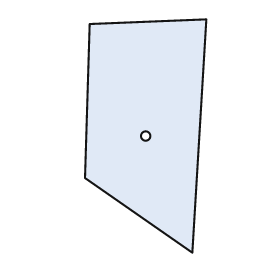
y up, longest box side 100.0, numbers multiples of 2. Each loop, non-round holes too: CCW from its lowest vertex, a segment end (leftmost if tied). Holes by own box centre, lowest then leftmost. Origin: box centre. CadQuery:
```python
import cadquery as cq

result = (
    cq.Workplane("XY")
    .moveTo(20.0, -50.0)
    .lineTo(26.0, 50.0)
    .lineTo(-24.0, 48.0)
    .lineTo(-26.0, -18.0)
    .close()
    .moveTo(0.0, 0.0)
    .circle(2.0)
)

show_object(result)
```